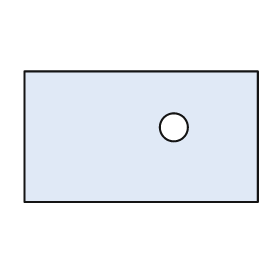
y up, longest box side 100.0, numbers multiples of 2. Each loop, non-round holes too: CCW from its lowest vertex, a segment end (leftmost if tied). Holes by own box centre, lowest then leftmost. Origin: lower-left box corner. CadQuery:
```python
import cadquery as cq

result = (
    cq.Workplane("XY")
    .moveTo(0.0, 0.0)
    .lineTo(100.0, 0.0)
    .lineTo(100.0, 56.0)
    .lineTo(0.0, 56.0)
    .close()
    .moveTo(64.0, 32.0)
    .circle(6.0)
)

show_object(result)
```